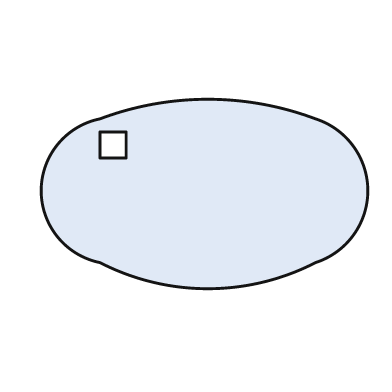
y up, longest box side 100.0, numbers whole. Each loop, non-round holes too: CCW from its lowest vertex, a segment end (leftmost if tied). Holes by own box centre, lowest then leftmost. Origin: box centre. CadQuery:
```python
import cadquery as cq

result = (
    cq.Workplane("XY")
    .moveTo(-32.0, -21.0)
    .threePointArc((1.0, -29.0), (34.0, -21.0))
    .threePointArc((50.0, 1.0), (34.0, 23.0))
    .threePointArc((1.0, 29.0), (-32.0, 23.0))
    .threePointArc((-50.0, 1.0), (-32.0, -21.0))
    .close()
    .moveTo(-32.0, 11.0)
    .lineTo(-24.0, 11.0)
    .lineTo(-24.0, 19.0)
    .lineTo(-32.0, 19.0)
    .close()
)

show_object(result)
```